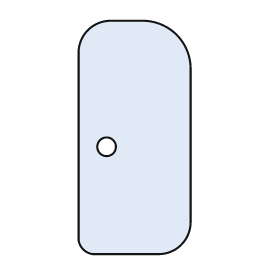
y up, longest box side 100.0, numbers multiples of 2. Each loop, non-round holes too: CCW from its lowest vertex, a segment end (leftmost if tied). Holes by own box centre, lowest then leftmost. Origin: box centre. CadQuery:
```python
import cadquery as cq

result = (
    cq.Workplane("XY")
    .moveTo(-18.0, -50.0)
    .lineTo(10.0, -50.0)
    .threePointArc((20.0, -46.0), (24.0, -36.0))
    .lineTo(24.0, 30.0)
    .threePointArc((18.0, 44.0), (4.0, 50.0))
    .lineTo(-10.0, 50.0)
    .threePointArc((-20.0, 46.0), (-24.0, 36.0))
    .lineTo(-24.0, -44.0)
    .threePointArc((-22.0, -48.0), (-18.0, -50.0))
    .close()
    .moveTo(-12.0, -4.0)
    .circle(4.0)
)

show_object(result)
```